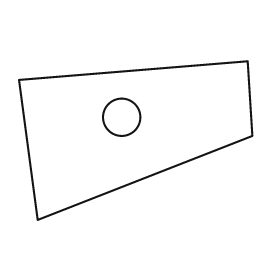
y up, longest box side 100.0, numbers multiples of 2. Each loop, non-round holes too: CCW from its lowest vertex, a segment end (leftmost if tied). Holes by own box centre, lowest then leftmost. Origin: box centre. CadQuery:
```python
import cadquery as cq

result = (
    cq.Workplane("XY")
    .moveTo(-42.0, -34.0)
    .lineTo(50.0, 2.0)
    .lineTo(48.0, 34.0)
    .lineTo(-50.0, 26.0)
    .close()
    .moveTo(-6.0, 10.0)
    .circle(8.0)
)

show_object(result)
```